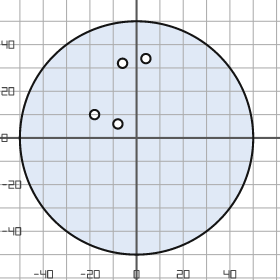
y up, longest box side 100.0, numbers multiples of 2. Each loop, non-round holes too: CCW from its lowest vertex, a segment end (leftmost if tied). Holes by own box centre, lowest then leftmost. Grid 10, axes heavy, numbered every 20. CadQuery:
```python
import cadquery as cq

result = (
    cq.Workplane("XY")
    .moveTo(0.0, 0.0)
    .circle(50.0)
    .moveTo(-8.0, 6.0)
    .circle(2.0)
    .moveTo(-18.0, 10.0)
    .circle(2.0)
    .moveTo(-6.0, 32.0)
    .circle(2.0)
    .moveTo(4.0, 34.0)
    .circle(2.0)
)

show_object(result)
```